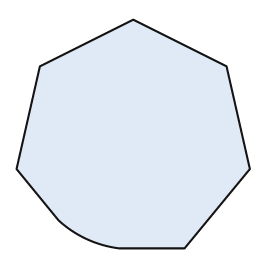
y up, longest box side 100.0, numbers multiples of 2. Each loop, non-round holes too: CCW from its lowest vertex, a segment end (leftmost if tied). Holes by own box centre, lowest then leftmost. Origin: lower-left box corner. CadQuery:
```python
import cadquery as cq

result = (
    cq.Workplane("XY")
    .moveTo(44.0, 0.0)
    .lineTo(72.0, 0.0)
    .lineTo(100.0, 34.0)
    .lineTo(90.0, 78.0)
    .lineTo(50.0, 98.0)
    .lineTo(10.0, 78.0)
    .lineTo(0.0, 34.0)
    .lineTo(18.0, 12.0)
    .threePointArc((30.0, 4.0), (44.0, 0.0))
    .close()
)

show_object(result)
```